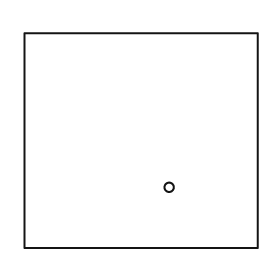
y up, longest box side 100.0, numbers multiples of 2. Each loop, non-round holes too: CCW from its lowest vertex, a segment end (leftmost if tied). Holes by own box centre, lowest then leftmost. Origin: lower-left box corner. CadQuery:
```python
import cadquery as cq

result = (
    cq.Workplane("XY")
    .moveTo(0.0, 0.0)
    .lineTo(100.0, 0.0)
    .lineTo(100.0, 92.0)
    .lineTo(0.0, 92.0)
    .close()
    .moveTo(62.0, 26.0)
    .circle(2.0)
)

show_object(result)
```